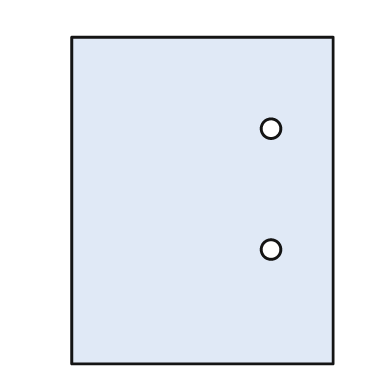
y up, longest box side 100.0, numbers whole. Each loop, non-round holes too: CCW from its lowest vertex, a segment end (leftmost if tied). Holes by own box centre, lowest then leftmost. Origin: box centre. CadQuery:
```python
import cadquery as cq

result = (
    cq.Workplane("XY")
    .moveTo(-40.0, -50.0)
    .lineTo(40.0, -50.0)
    .lineTo(40.0, 50.0)
    .lineTo(-40.0, 50.0)
    .close()
    .moveTo(21.0, -15.0)
    .circle(3.0)
    .moveTo(21.0, 22.0)
    .circle(3.0)
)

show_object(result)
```